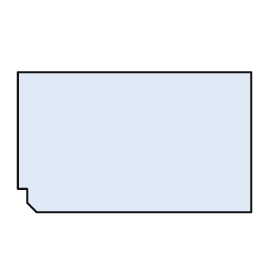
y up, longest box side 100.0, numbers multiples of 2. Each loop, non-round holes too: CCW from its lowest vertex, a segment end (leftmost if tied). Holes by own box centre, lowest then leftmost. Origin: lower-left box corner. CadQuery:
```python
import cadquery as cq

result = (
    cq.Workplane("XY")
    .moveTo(8.0, 0.0)
    .lineTo(100.0, 0.0)
    .lineTo(100.0, 60.0)
    .lineTo(0.0, 60.0)
    .lineTo(0.0, 10.0)
    .lineTo(4.0, 10.0)
    .lineTo(4.0, 4.0)
    .close()
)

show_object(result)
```